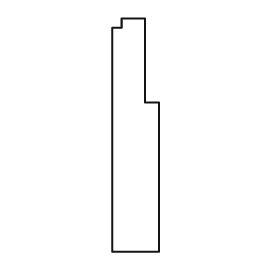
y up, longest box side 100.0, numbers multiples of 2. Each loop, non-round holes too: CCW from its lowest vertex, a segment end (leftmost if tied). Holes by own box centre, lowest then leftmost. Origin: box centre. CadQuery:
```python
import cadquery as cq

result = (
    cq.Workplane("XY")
    .moveTo(-10.0, -50.0)
    .lineTo(10.0, -50.0)
    .lineTo(10.0, 14.0)
    .lineTo(4.0, 14.0)
    .lineTo(4.0, 50.0)
    .lineTo(-6.0, 50.0)
    .lineTo(-6.0, 46.0)
    .lineTo(-10.0, 46.0)
    .close()
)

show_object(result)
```